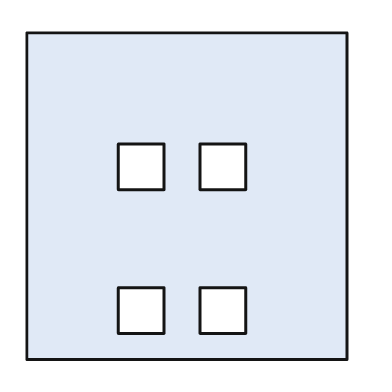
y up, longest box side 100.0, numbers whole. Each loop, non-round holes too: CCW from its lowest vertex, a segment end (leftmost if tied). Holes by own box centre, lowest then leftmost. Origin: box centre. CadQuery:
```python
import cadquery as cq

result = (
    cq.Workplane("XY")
    .moveTo(-49.0, -50.0)
    .lineTo(49.0, -50.0)
    .lineTo(49.0, 50.0)
    .lineTo(-49.0, 50.0)
    .close()
    .moveTo(-21.0, -42.0)
    .lineTo(-7.0, -42.0)
    .lineTo(-7.0, -28.0)
    .lineTo(-21.0, -28.0)
    .close()
    .moveTo(4.0, -42.0)
    .lineTo(18.0, -42.0)
    .lineTo(18.0, -28.0)
    .lineTo(4.0, -28.0)
    .close()
    .moveTo(-21.0, 2.0)
    .lineTo(-7.0, 2.0)
    .lineTo(-7.0, 16.0)
    .lineTo(-21.0, 16.0)
    .close()
    .moveTo(4.0, 2.0)
    .lineTo(18.0, 2.0)
    .lineTo(18.0, 16.0)
    .lineTo(4.0, 16.0)
    .close()
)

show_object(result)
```